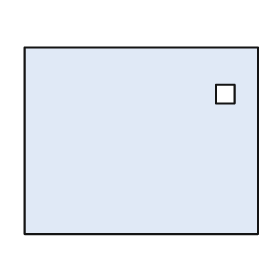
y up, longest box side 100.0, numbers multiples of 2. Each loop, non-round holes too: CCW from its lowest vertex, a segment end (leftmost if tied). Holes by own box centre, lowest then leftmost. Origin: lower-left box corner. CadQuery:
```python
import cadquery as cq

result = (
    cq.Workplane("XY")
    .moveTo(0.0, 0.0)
    .lineTo(100.0, 0.0)
    .lineTo(100.0, 80.0)
    .lineTo(0.0, 80.0)
    .close()
    .moveTo(82.0, 56.0)
    .lineTo(90.0, 56.0)
    .lineTo(90.0, 64.0)
    .lineTo(82.0, 64.0)
    .close()
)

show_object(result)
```